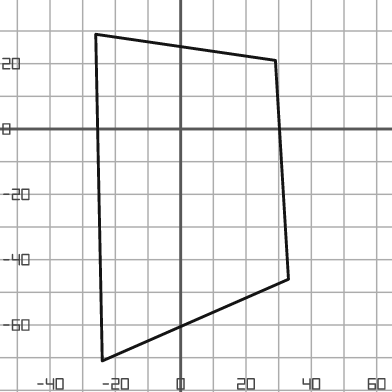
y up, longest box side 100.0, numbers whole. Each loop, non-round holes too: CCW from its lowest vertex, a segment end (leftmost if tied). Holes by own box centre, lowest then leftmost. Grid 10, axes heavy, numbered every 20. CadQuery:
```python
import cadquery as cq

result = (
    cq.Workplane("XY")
    .moveTo(-24.0, -71.0)
    .lineTo(33.0, -46.0)
    .lineTo(29.0, 21.0)
    .lineTo(-26.0, 29.0)
    .close()
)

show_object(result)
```